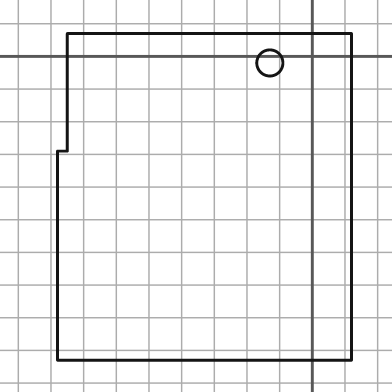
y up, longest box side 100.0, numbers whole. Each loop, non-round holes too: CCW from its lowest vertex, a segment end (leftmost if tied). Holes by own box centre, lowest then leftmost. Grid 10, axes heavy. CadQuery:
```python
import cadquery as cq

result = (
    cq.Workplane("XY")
    .moveTo(-78.0, -93.0)
    .lineTo(12.0, -93.0)
    .lineTo(12.0, 7.0)
    .lineTo(-75.0, 7.0)
    .lineTo(-75.0, -29.0)
    .lineTo(-78.0, -29.0)
    .close()
    .moveTo(-13.0, -2.0)
    .circle(4.0)
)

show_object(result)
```